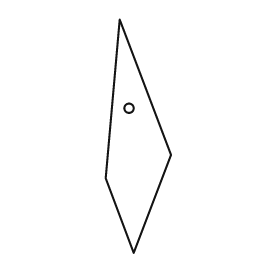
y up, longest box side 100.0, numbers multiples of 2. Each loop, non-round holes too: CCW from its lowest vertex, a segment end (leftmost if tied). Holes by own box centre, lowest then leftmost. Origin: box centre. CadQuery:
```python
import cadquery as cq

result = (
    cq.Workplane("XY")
    .moveTo(-2.0, -50.0)
    .lineTo(14.0, -8.0)
    .lineTo(-8.0, 50.0)
    .lineTo(-14.0, -18.0)
    .close()
    .moveTo(-4.0, 12.0)
    .circle(2.0)
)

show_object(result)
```